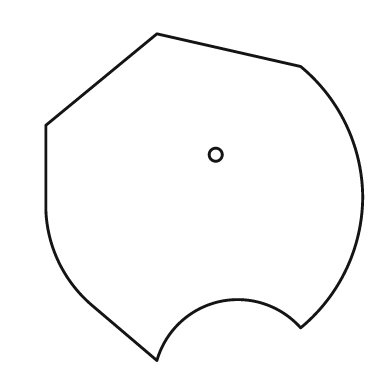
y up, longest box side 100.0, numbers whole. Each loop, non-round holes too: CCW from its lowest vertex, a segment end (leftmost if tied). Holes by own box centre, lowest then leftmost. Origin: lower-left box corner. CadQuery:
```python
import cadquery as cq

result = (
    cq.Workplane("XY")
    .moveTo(34.0, 0.0)
    .threePointArc((53.0, 18.0), (78.0, 10.0))
    .threePointArc((92.0, 28.0), (97.0, 50.0))
    .threePointArc((92.0, 72.0), (78.0, 90.0))
    .lineTo(34.0, 100.0)
    .lineTo(0.0, 72.0)
    .lineTo(0.0, 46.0)
    .threePointArc((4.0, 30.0), (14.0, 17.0))
    .close()
    .moveTo(52.0, 63.0)
    .circle(2.0)
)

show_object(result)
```